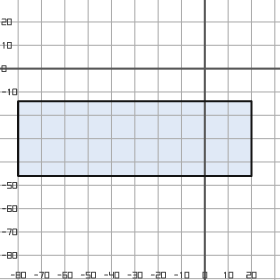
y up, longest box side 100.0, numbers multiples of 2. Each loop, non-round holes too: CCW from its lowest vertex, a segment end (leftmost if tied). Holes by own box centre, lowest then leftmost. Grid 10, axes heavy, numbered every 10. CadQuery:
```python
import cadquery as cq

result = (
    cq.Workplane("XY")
    .moveTo(-80.0, -46.0)
    .lineTo(20.0, -46.0)
    .lineTo(20.0, -14.0)
    .lineTo(-80.0, -14.0)
    .close()
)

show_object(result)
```